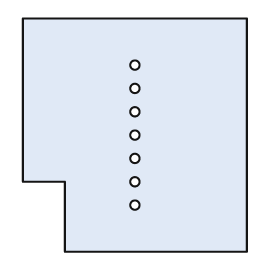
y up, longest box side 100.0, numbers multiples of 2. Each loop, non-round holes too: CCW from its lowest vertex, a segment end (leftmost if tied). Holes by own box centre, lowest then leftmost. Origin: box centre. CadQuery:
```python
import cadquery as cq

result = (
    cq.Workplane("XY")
    .moveTo(-30.0, -50.0)
    .lineTo(48.0, -50.0)
    .lineTo(48.0, 50.0)
    .lineTo(-48.0, 50.0)
    .lineTo(-48.0, -20.0)
    .lineTo(-30.0, -20.0)
    .close()
    .moveTo(0.0, -30.0)
    .circle(2.0)
    .moveTo(0.0, -20.0)
    .circle(2.0)
    .moveTo(0.0, -10.0)
    .circle(2.0)
    .moveTo(0.0, 0.0)
    .circle(2.0)
    .moveTo(0.0, 10.0)
    .circle(2.0)
    .moveTo(0.0, 20.0)
    .circle(2.0)
    .moveTo(0.0, 30.0)
    .circle(2.0)
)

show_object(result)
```